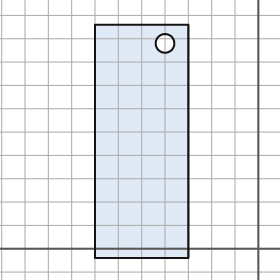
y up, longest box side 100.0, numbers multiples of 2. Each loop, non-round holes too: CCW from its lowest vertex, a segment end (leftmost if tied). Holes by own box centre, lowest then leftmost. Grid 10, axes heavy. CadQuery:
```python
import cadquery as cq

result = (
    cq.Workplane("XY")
    .moveTo(-70.0, -4.0)
    .lineTo(-30.0, -4.0)
    .lineTo(-30.0, 96.0)
    .lineTo(-70.0, 96.0)
    .close()
    .moveTo(-40.0, 88.0)
    .circle(4.0)
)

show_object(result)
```